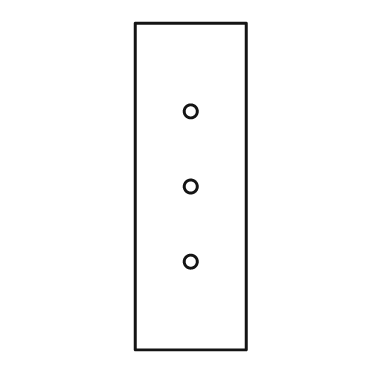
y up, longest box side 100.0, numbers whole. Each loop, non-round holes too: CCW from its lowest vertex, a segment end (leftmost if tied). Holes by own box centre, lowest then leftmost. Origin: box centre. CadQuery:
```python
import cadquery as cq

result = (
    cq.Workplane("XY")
    .moveTo(-17.0, -50.0)
    .lineTo(17.0, -50.0)
    .lineTo(17.0, 50.0)
    .lineTo(-17.0, 50.0)
    .close()
    .moveTo(0.0, -23.0)
    .circle(2.0)
    .moveTo(0.0, 0.0)
    .circle(2.0)
    .moveTo(0.0, 23.0)
    .circle(2.0)
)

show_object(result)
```